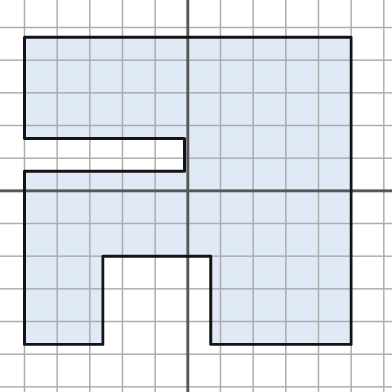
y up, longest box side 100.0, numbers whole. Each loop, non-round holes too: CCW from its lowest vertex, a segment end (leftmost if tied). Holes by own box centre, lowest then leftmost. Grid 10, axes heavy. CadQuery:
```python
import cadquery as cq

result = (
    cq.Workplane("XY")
    .moveTo(-50.0, -47.0)
    .lineTo(-26.0, -47.0)
    .lineTo(-26.0, -20.0)
    .lineTo(7.0, -20.0)
    .lineTo(7.0, -47.0)
    .lineTo(50.0, -47.0)
    .lineTo(50.0, 47.0)
    .lineTo(-50.0, 47.0)
    .lineTo(-50.0, 16.0)
    .lineTo(-1.0, 16.0)
    .lineTo(-1.0, 6.0)
    .lineTo(-50.0, 6.0)
    .close()
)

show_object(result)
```